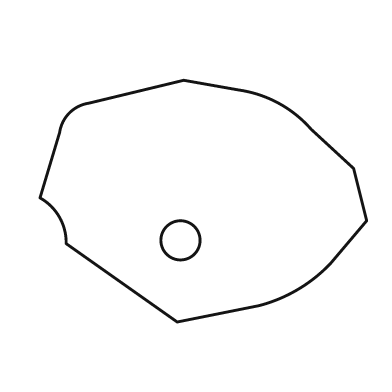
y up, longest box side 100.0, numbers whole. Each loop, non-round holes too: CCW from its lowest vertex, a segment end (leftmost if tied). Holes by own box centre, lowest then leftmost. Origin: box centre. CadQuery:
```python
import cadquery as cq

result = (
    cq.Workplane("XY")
    .moveTo(-8.0, -37.0)
    .lineTo(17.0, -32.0)
    .threePointArc((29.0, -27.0), (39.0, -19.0))
    .lineTo(50.0, -6.0)
    .lineTo(46.0, 10.0)
    .lineTo(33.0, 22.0)
    .threePointArc((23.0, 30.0), (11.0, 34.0))
    .lineTo(-6.0, 37.0)
    .lineTo(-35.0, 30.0)
    .threePointArc((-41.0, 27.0), (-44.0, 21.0))
    .lineTo(-50.0, 1.0)
    .threePointArc((-44.0, -5.0), (-42.0, -13.0))
    .close()
    .moveTo(-7.0, -12.0)
    .circle(6.0)
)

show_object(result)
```